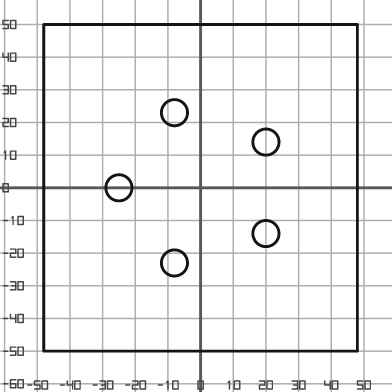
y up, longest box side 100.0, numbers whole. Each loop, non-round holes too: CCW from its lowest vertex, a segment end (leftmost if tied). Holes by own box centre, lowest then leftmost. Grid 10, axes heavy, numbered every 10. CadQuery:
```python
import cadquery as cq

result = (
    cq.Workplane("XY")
    .moveTo(-48.0, -50.0)
    .lineTo(48.0, -50.0)
    .lineTo(48.0, 50.0)
    .lineTo(-48.0, 50.0)
    .close()
    .moveTo(-8.0, -23.0)
    .circle(4.0)
    .moveTo(20.0, -14.0)
    .circle(4.0)
    .moveTo(-25.0, 0.0)
    .circle(4.0)
    .moveTo(20.0, 14.0)
    .circle(4.0)
    .moveTo(-8.0, 23.0)
    .circle(4.0)
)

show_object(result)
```